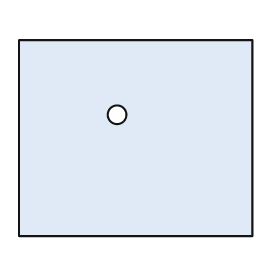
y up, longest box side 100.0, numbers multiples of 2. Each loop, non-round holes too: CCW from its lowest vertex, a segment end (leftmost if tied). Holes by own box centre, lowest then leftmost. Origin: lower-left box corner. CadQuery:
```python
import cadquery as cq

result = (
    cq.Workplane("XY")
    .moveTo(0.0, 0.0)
    .lineTo(100.0, 0.0)
    .lineTo(100.0, 84.0)
    .lineTo(0.0, 84.0)
    .close()
    .moveTo(42.0, 52.0)
    .circle(4.0)
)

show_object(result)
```